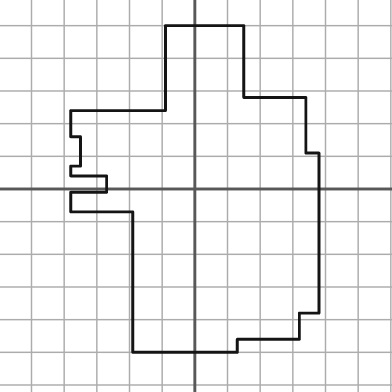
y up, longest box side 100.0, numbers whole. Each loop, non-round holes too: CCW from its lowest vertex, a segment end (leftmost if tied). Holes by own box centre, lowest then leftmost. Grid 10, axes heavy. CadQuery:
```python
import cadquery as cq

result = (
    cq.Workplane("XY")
    .moveTo(-19.0, -50.0)
    .lineTo(13.0, -50.0)
    .lineTo(13.0, -46.0)
    .lineTo(32.0, -46.0)
    .lineTo(32.0, -38.0)
    .lineTo(38.0, -38.0)
    .lineTo(38.0, 11.0)
    .lineTo(34.0, 11.0)
    .lineTo(34.0, 28.0)
    .lineTo(15.0, 28.0)
    .lineTo(15.0, 50.0)
    .lineTo(-9.0, 50.0)
    .lineTo(-9.0, 24.0)
    .lineTo(-38.0, 24.0)
    .lineTo(-38.0, 16.0)
    .lineTo(-35.0, 16.0)
    .lineTo(-35.0, 7.0)
    .lineTo(-38.0, 7.0)
    .lineTo(-38.0, 4.0)
    .lineTo(-27.0, 4.0)
    .lineTo(-27.0, -1.0)
    .lineTo(-38.0, -1.0)
    .lineTo(-38.0, -7.0)
    .lineTo(-19.0, -7.0)
    .close()
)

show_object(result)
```